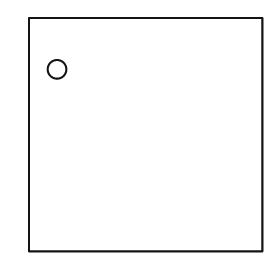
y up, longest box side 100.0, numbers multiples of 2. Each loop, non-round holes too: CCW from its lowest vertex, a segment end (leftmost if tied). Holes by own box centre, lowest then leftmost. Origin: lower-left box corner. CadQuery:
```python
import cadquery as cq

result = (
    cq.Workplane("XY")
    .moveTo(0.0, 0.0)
    .lineTo(100.0, 0.0)
    .lineTo(100.0, 100.0)
    .lineTo(0.0, 100.0)
    .close()
    .moveTo(12.0, 78.0)
    .circle(4.0)
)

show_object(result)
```